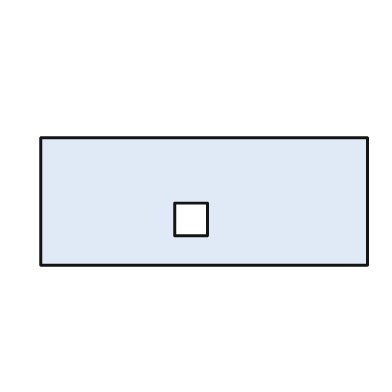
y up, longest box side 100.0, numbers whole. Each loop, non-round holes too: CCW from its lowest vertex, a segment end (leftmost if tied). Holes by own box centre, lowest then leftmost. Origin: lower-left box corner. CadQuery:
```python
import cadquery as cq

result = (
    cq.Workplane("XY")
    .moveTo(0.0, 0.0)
    .lineTo(100.0, 0.0)
    .lineTo(100.0, 39.0)
    .lineTo(0.0, 39.0)
    .close()
    .moveTo(41.0, 9.0)
    .lineTo(51.0, 9.0)
    .lineTo(51.0, 19.0)
    .lineTo(41.0, 19.0)
    .close()
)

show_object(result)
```